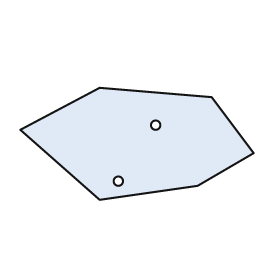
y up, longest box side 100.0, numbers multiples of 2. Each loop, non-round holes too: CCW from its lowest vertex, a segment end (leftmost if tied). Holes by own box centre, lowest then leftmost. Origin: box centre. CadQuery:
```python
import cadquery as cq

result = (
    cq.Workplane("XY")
    .moveTo(-16.0, -24.0)
    .lineTo(26.0, -18.0)
    .lineTo(50.0, -4.0)
    .lineTo(32.0, 20.0)
    .lineTo(-16.0, 24.0)
    .lineTo(-50.0, 6.0)
    .close()
    .moveTo(-8.0, -16.0)
    .circle(2.0)
    .moveTo(8.0, 8.0)
    .circle(2.0)
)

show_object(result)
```